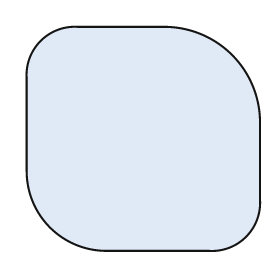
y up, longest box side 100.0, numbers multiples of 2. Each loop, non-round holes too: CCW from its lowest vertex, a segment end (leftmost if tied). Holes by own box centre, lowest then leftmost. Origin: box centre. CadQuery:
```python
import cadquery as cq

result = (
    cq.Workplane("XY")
    .moveTo(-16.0, -48.0)
    .lineTo(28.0, -48.0)
    .threePointArc((44.0, -42.0), (50.0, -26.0))
    .lineTo(50.0, 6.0)
    .threePointArc((38.0, 36.0), (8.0, 48.0))
    .lineTo(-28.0, 48.0)
    .threePointArc((-44.0, 42.0), (-50.0, 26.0))
    .lineTo(-50.0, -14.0)
    .threePointArc((-40.0, -38.0), (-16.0, -48.0))
    .close()
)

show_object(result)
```